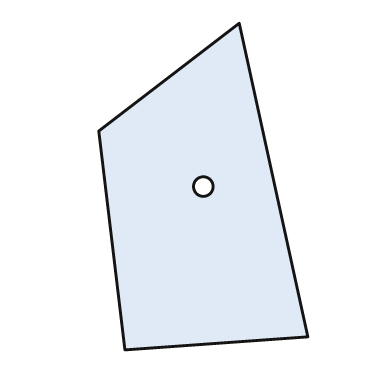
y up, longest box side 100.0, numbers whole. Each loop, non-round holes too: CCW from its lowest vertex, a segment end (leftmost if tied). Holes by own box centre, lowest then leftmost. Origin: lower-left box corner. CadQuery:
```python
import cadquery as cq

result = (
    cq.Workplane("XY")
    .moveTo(8.0, 0.0)
    .lineTo(64.0, 4.0)
    .lineTo(43.0, 100.0)
    .lineTo(0.0, 67.0)
    .close()
    .moveTo(32.0, 50.0)
    .circle(3.0)
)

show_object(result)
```